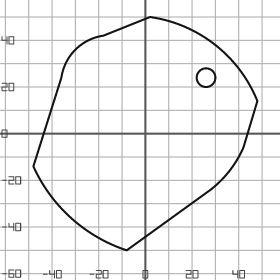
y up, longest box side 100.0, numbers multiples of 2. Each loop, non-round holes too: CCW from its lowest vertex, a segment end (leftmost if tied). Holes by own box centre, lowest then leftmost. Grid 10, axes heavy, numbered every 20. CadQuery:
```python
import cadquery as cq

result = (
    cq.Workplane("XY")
    .moveTo(-8.0, -50.0)
    .lineTo(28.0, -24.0)
    .threePointArc((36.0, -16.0), (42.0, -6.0))
    .lineTo(48.0, 14.0)
    .threePointArc((30.0, 38.0), (2.0, 50.0))
    .lineTo(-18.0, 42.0)
    .threePointArc((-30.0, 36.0), (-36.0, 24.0))
    .lineTo(-48.0, -14.0)
    .threePointArc((-32.0, -36.0), (-8.0, -50.0))
    .close()
    .moveTo(26.0, 24.0)
    .circle(4.0)
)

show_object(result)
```